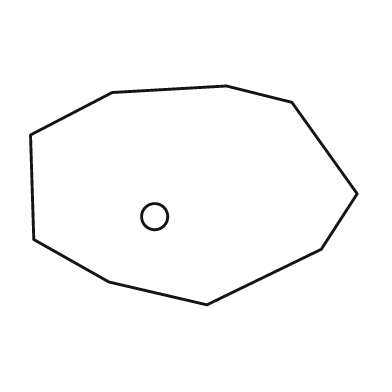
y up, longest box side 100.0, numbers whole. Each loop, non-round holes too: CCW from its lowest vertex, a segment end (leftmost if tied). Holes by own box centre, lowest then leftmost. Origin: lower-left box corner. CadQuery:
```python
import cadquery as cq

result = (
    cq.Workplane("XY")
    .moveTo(54.0, 0.0)
    .lineTo(89.0, 17.0)
    .lineTo(100.0, 34.0)
    .lineTo(80.0, 62.0)
    .lineTo(60.0, 67.0)
    .lineTo(25.0, 65.0)
    .lineTo(0.0, 52.0)
    .lineTo(1.0, 20.0)
    .lineTo(24.0, 7.0)
    .close()
    .moveTo(38.0, 27.0)
    .circle(4.0)
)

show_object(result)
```